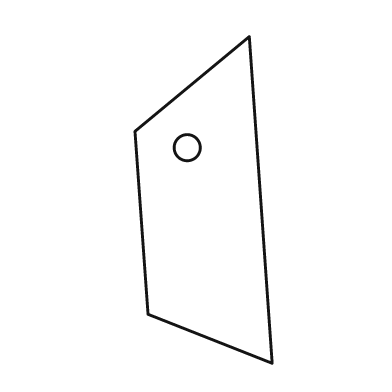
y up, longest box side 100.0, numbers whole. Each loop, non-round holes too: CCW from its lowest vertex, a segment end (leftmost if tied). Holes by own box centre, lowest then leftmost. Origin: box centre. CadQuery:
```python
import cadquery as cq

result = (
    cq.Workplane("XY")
    .moveTo(21.0, -50.0)
    .lineTo(14.0, 50.0)
    .lineTo(-21.0, 21.0)
    .lineTo(-17.0, -35.0)
    .close()
    .moveTo(-5.0, 16.0)
    .circle(4.0)
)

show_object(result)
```